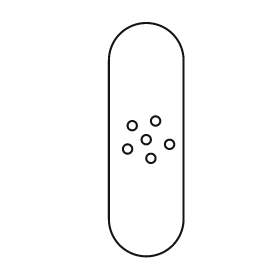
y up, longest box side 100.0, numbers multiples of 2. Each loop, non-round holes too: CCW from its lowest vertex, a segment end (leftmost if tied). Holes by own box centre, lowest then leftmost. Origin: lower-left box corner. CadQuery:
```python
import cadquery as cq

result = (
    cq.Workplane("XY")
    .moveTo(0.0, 16.0)
    .threePointArc((16.0, 0.0), (32.0, 16.0))
    .lineTo(32.0, 84.0)
    .threePointArc((16.0, 100.0), (0.0, 84.0))
    .close()
    .moveTo(18.0, 42.0)
    .circle(2.0)
    .moveTo(8.0, 46.0)
    .circle(2.0)
    .moveTo(26.0, 48.0)
    .circle(2.0)
    .moveTo(16.0, 50.0)
    .circle(2.0)
    .moveTo(10.0, 56.0)
    .circle(2.0)
    .moveTo(20.0, 58.0)
    .circle(2.0)
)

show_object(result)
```